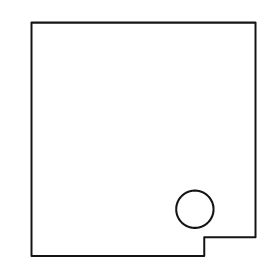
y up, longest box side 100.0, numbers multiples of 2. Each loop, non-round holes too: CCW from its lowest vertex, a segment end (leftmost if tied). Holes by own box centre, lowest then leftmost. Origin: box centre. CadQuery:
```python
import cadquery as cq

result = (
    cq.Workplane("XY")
    .moveTo(-48.0, -50.0)
    .lineTo(26.0, -50.0)
    .lineTo(26.0, -42.0)
    .lineTo(48.0, -42.0)
    .lineTo(48.0, 50.0)
    .lineTo(-48.0, 50.0)
    .close()
    .moveTo(22.0, -30.0)
    .circle(8.0)
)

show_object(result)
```